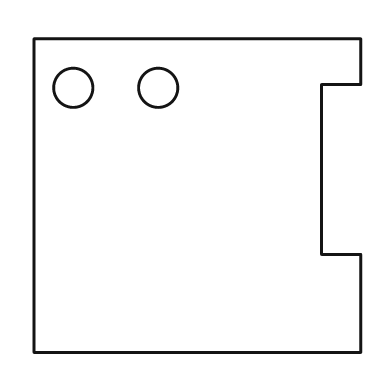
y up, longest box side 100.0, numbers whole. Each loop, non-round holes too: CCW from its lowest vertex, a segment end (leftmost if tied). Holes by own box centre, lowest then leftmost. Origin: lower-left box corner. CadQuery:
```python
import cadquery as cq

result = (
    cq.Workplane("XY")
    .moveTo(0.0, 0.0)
    .lineTo(100.0, 0.0)
    .lineTo(100.0, 30.0)
    .lineTo(88.0, 30.0)
    .lineTo(88.0, 82.0)
    .lineTo(100.0, 82.0)
    .lineTo(100.0, 96.0)
    .lineTo(0.0, 96.0)
    .close()
    .moveTo(12.0, 81.0)
    .circle(6.0)
    .moveTo(38.0, 81.0)
    .circle(6.0)
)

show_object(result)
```